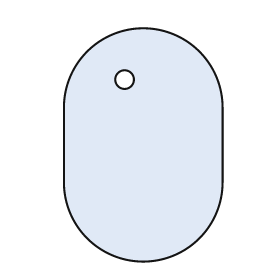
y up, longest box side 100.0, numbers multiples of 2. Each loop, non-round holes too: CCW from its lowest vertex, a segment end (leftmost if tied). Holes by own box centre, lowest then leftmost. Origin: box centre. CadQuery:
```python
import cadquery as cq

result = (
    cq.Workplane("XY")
    .moveTo(-34.0, -16.0)
    .threePointArc((0.0, -50.0), (34.0, -16.0))
    .lineTo(34.0, 16.0)
    .threePointArc((0.0, 50.0), (-34.0, 16.0))
    .close()
    .moveTo(-8.0, 28.0)
    .circle(4.0)
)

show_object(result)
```